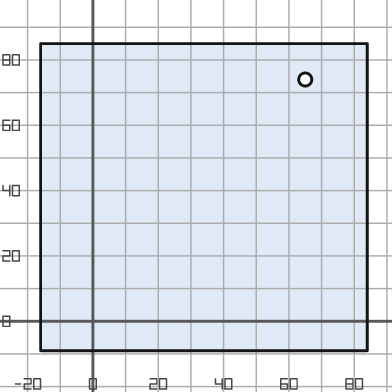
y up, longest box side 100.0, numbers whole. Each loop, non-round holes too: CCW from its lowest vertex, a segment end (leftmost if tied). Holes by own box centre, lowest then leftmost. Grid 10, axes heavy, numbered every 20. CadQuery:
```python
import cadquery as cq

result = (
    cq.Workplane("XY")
    .moveTo(-16.0, -9.0)
    .lineTo(84.0, -9.0)
    .lineTo(84.0, 85.0)
    .lineTo(-16.0, 85.0)
    .close()
    .moveTo(65.0, 74.0)
    .circle(2.0)
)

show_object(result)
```